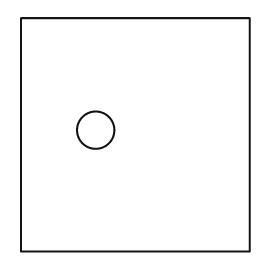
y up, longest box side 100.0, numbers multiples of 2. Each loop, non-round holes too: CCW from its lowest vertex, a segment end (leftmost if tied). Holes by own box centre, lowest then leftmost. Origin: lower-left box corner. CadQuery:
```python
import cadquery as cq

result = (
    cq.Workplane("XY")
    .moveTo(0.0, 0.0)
    .lineTo(98.0, 0.0)
    .lineTo(98.0, 100.0)
    .lineTo(0.0, 100.0)
    .close()
    .moveTo(32.0, 52.0)
    .circle(8.0)
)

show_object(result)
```